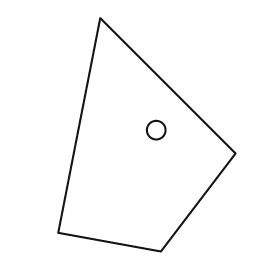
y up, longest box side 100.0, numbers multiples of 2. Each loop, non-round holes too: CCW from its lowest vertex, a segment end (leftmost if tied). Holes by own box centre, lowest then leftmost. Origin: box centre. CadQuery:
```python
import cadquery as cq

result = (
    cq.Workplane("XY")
    .moveTo(6.0, -50.0)
    .lineTo(38.0, -8.0)
    .lineTo(-20.0, 50.0)
    .lineTo(-38.0, -42.0)
    .close()
    .moveTo(4.0, 2.0)
    .circle(4.0)
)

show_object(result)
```